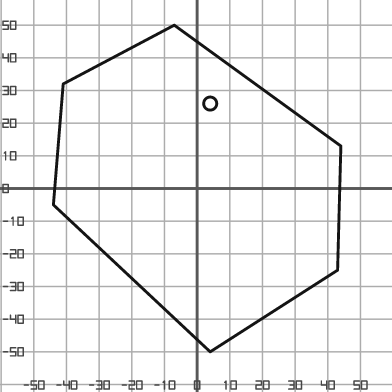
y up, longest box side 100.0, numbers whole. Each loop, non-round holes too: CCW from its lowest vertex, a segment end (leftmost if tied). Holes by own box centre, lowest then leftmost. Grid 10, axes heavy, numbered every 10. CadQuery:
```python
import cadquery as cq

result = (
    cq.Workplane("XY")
    .moveTo(4.0, -50.0)
    .lineTo(43.0, -25.0)
    .lineTo(44.0, 13.0)
    .lineTo(-7.0, 50.0)
    .lineTo(-41.0, 32.0)
    .lineTo(-44.0, -5.0)
    .close()
    .moveTo(4.0, 26.0)
    .circle(2.0)
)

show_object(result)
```